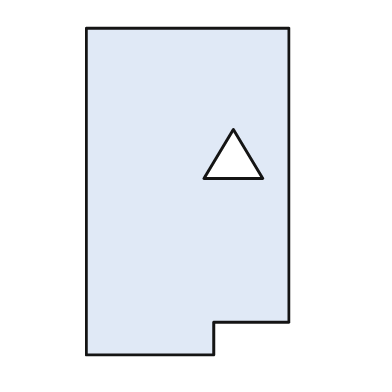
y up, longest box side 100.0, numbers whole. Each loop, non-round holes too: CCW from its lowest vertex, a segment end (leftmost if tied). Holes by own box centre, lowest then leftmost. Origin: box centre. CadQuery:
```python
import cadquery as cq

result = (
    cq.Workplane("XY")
    .moveTo(-31.0, -50.0)
    .lineTo(8.0, -50.0)
    .lineTo(8.0, -40.0)
    .lineTo(31.0, -40.0)
    .lineTo(31.0, 50.0)
    .lineTo(-31.0, 50.0)
    .close()
    .moveTo(5.0, 4.0)
    .lineTo(23.0, 4.0)
    .lineTo(14.0, 19.0)
    .close()
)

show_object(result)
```